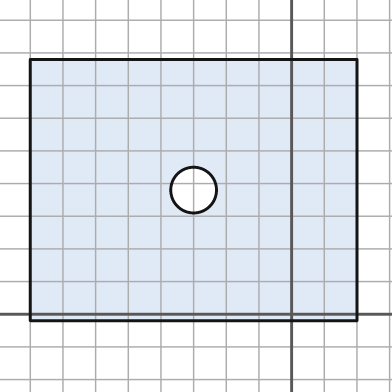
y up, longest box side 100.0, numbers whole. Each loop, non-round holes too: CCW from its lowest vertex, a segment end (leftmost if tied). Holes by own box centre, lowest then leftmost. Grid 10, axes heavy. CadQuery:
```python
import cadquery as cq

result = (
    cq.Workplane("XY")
    .moveTo(-80.0, -2.0)
    .lineTo(20.0, -2.0)
    .lineTo(20.0, 78.0)
    .lineTo(-80.0, 78.0)
    .close()
    .moveTo(-30.0, 38.0)
    .circle(7.0)
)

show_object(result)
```